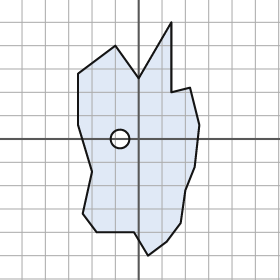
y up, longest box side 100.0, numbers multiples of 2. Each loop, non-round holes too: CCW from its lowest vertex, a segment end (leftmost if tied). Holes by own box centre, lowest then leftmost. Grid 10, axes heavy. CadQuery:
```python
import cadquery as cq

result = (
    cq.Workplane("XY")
    .moveTo(4.0, -50.0)
    .lineTo(12.0, -44.0)
    .lineTo(18.0, -36.0)
    .lineTo(20.0, -22.0)
    .lineTo(24.0, -12.0)
    .lineTo(26.0, 6.0)
    .lineTo(22.0, 22.0)
    .lineTo(14.0, 20.0)
    .lineTo(14.0, 50.0)
    .lineTo(0.0, 26.0)
    .lineTo(-10.0, 40.0)
    .lineTo(-26.0, 28.0)
    .lineTo(-26.0, 6.0)
    .lineTo(-20.0, -14.0)
    .lineTo(-24.0, -32.0)
    .lineTo(-18.0, -40.0)
    .lineTo(-2.0, -40.0)
    .close()
    .moveTo(-8.0, 0.0)
    .circle(4.0)
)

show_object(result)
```